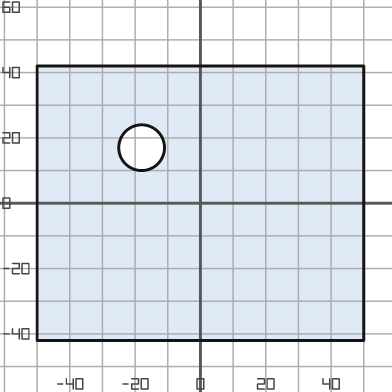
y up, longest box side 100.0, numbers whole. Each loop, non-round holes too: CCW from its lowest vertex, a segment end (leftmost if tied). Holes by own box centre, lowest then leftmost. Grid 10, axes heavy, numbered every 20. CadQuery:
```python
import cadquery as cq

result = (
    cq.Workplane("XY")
    .moveTo(-50.0, -42.0)
    .lineTo(50.0, -42.0)
    .lineTo(50.0, 42.0)
    .lineTo(-50.0, 42.0)
    .close()
    .moveTo(-18.0, 17.0)
    .circle(7.0)
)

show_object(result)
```